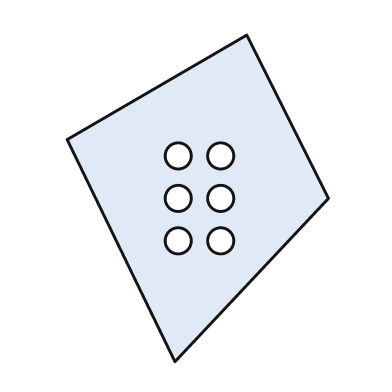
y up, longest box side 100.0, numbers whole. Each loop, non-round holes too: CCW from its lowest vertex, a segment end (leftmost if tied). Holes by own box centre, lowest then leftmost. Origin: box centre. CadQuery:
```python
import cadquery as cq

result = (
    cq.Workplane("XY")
    .moveTo(-7.0, -50.0)
    .lineTo(40.0, 0.0)
    .lineTo(15.0, 50.0)
    .lineTo(-40.0, 18.0)
    .close()
    .moveTo(-6.0, -13.0)
    .circle(4.0)
    .moveTo(7.0, -13.0)
    .circle(4.0)
    .moveTo(-6.0, 0.0)
    .circle(4.0)
    .moveTo(7.0, 0.0)
    .circle(4.0)
    .moveTo(-6.0, 13.0)
    .circle(4.0)
    .moveTo(7.0, 13.0)
    .circle(4.0)
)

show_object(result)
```